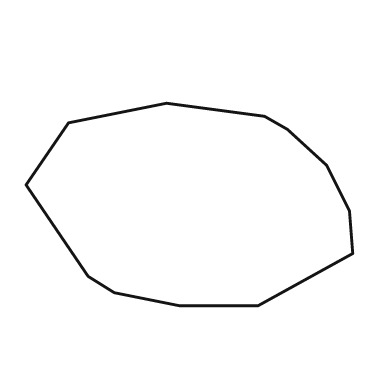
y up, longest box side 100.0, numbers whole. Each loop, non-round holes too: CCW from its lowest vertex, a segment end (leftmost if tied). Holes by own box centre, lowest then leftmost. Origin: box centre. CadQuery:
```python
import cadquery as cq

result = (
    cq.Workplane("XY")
    .moveTo(-3.0, -31.0)
    .lineTo(21.0, -31.0)
    .lineTo(50.0, -15.0)
    .lineTo(49.0, -2.0)
    .lineTo(42.0, 12.0)
    .lineTo(30.0, 23.0)
    .lineTo(23.0, 27.0)
    .lineTo(-7.0, 31.0)
    .lineTo(-37.0, 25.0)
    .lineTo(-50.0, 6.0)
    .lineTo(-31.0, -22.0)
    .lineTo(-23.0, -27.0)
    .close()
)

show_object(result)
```